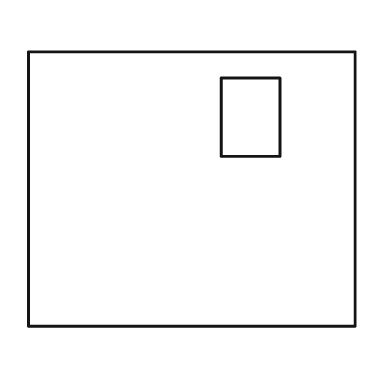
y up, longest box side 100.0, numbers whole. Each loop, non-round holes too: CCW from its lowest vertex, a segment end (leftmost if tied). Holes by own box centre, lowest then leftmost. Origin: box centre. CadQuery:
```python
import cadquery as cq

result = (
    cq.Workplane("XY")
    .moveTo(-50.0, -42.0)
    .lineTo(50.0, -42.0)
    .lineTo(50.0, 42.0)
    .lineTo(-50.0, 42.0)
    .close()
    .moveTo(9.0, 10.0)
    .lineTo(27.0, 10.0)
    .lineTo(27.0, 34.0)
    .lineTo(9.0, 34.0)
    .close()
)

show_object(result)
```